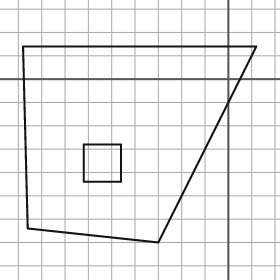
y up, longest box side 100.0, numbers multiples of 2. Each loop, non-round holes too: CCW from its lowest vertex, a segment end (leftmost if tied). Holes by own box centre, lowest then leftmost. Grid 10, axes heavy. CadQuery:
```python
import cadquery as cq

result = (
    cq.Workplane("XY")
    .moveTo(-30.0, -70.0)
    .lineTo(12.0, 14.0)
    .lineTo(-88.0, 14.0)
    .lineTo(-86.0, -64.0)
    .close()
    .moveTo(-62.0, -44.0)
    .lineTo(-46.0, -44.0)
    .lineTo(-46.0, -28.0)
    .lineTo(-62.0, -28.0)
    .close()
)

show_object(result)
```